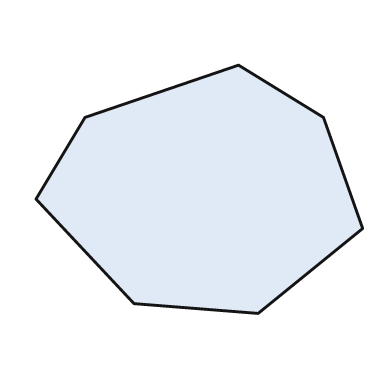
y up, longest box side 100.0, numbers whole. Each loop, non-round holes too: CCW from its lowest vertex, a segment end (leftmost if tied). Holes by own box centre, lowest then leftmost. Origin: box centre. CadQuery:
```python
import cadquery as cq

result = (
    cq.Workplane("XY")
    .moveTo(18.0, -38.0)
    .lineTo(50.0, -12.0)
    .lineTo(38.0, 22.0)
    .lineTo(12.0, 38.0)
    .lineTo(-35.0, 22.0)
    .lineTo(-50.0, -3.0)
    .lineTo(-20.0, -35.0)
    .close()
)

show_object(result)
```